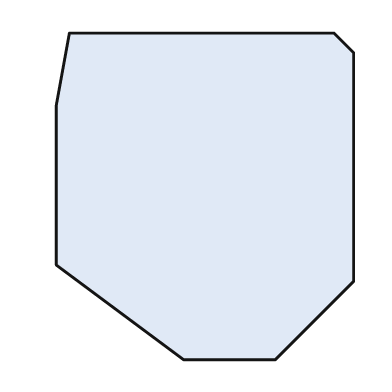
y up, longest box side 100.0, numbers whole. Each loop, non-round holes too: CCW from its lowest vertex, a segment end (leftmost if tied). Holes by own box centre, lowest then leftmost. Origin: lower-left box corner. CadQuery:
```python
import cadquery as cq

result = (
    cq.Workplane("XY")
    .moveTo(39.0, 0.0)
    .lineTo(67.0, 0.0)
    .lineTo(91.0, 24.0)
    .lineTo(91.0, 94.0)
    .lineTo(85.0, 100.0)
    .lineTo(4.0, 100.0)
    .lineTo(0.0, 78.0)
    .lineTo(0.0, 29.0)
    .close()
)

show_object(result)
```